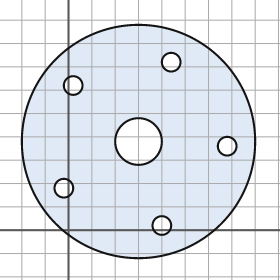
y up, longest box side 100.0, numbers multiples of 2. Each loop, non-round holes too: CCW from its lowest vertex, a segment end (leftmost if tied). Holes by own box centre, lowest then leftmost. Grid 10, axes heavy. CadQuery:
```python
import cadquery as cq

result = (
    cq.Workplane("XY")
    .moveTo(30.0, 38.0)
    .circle(50.0)
    .moveTo(40.0, 2.0)
    .circle(4.0)
    .moveTo(-2.0, 18.0)
    .circle(4.0)
    .moveTo(68.0, 36.0)
    .circle(4.0)
    .moveTo(30.0, 38.0)
    .circle(10.0)
    .moveTo(2.0, 62.0)
    .circle(4.0)
    .moveTo(44.0, 72.0)
    .circle(4.0)
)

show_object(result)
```